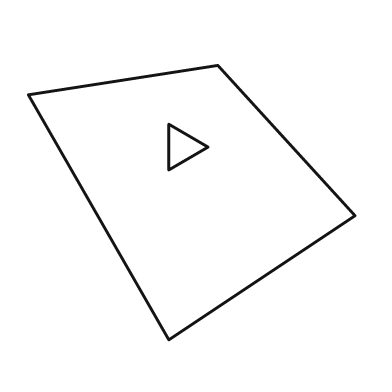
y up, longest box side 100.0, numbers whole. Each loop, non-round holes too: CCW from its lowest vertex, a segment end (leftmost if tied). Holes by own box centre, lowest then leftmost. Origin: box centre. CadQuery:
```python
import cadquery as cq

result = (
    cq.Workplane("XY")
    .moveTo(-7.0, -42.0)
    .lineTo(50.0, -4.0)
    .lineTo(8.0, 42.0)
    .lineTo(-50.0, 33.0)
    .close()
    .moveTo(-7.0, 10.0)
    .lineTo(5.0, 17.0)
    .lineTo(-7.0, 24.0)
    .close()
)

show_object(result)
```